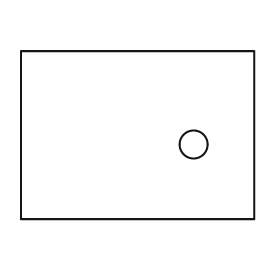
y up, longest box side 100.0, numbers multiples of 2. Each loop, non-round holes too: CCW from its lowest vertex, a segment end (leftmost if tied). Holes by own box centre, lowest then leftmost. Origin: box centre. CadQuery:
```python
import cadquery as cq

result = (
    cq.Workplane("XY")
    .moveTo(-50.0, -36.0)
    .lineTo(50.0, -36.0)
    .lineTo(50.0, 36.0)
    .lineTo(-50.0, 36.0)
    .close()
    .moveTo(24.0, -4.0)
    .circle(6.0)
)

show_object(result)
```